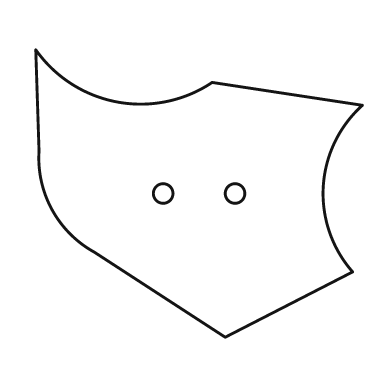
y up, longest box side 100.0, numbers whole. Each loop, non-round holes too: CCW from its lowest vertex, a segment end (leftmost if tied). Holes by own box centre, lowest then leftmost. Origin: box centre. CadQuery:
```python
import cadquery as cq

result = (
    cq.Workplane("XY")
    .moveTo(8.0, -44.0)
    .lineTo(47.0, -24.0)
    .threePointArc((38.0, 2.0), (50.0, 27.0))
    .lineTo(4.0, 34.0)
    .threePointArc((-25.0, 28.0), (-50.0, 44.0))
    .lineTo(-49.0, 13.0)
    .threePointArc((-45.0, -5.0), (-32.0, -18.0))
    .close()
    .moveTo(-11.0, 0.0)
    .circle(3.0)
    .moveTo(11.0, 0.0)
    .circle(3.0)
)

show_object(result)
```